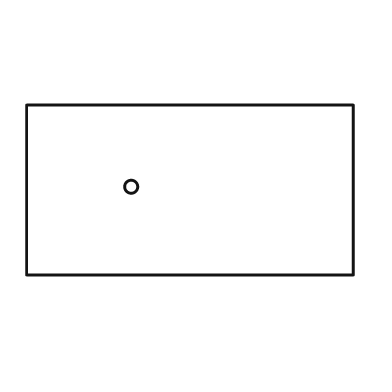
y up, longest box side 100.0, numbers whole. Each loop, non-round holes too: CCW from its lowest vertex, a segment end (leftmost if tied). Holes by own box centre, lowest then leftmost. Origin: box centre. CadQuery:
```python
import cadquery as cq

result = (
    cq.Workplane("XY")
    .moveTo(-50.0, -26.0)
    .lineTo(50.0, -26.0)
    .lineTo(50.0, 26.0)
    .lineTo(-50.0, 26.0)
    .close()
    .moveTo(-18.0, 1.0)
    .circle(2.0)
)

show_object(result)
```